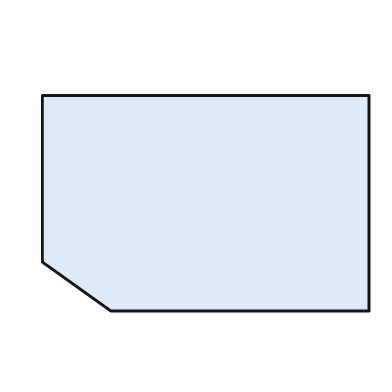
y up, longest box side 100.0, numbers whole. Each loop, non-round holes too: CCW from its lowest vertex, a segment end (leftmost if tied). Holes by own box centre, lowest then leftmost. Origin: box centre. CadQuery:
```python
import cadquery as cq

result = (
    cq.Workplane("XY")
    .moveTo(-29.0, -33.0)
    .lineTo(50.0, -33.0)
    .lineTo(50.0, 33.0)
    .lineTo(-50.0, 33.0)
    .lineTo(-50.0, -18.0)
    .close()
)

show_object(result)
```